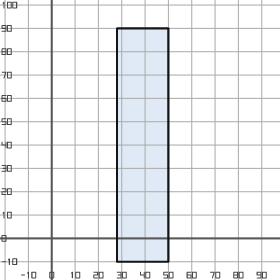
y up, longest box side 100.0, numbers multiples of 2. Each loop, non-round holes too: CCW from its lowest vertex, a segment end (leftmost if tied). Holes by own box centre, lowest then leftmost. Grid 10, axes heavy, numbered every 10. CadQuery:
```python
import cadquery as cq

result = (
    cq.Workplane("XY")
    .moveTo(28.0, -10.0)
    .lineTo(50.0, -10.0)
    .lineTo(50.0, 90.0)
    .lineTo(28.0, 90.0)
    .close()
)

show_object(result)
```